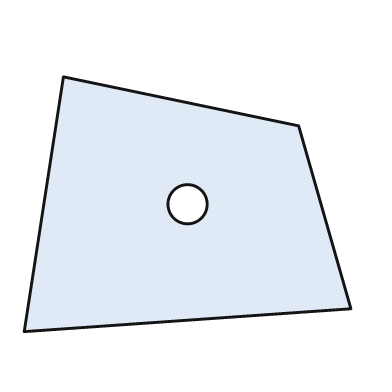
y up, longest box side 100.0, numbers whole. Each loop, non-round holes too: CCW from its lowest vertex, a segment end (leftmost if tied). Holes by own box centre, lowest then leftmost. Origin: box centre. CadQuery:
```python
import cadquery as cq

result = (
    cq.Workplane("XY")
    .moveTo(-50.0, -39.0)
    .lineTo(50.0, -32.0)
    .lineTo(34.0, 24.0)
    .lineTo(-38.0, 39.0)
    .close()
    .moveTo(0.0, 0.0)
    .circle(6.0)
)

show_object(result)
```